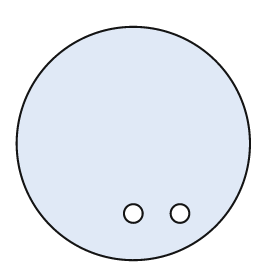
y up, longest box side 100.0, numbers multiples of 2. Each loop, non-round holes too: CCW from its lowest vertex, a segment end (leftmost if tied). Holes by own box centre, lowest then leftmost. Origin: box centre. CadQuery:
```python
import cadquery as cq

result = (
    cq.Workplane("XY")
    .moveTo(0.0, 0.0)
    .circle(50.0)
    .moveTo(0.0, -30.0)
    .circle(4.0)
    .moveTo(20.0, -30.0)
    .circle(4.0)
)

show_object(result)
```